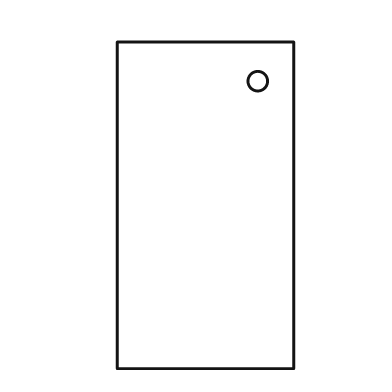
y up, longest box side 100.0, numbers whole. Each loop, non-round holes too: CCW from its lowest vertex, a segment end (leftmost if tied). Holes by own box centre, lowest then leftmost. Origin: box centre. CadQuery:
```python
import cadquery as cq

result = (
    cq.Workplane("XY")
    .moveTo(-27.0, -50.0)
    .lineTo(27.0, -50.0)
    .lineTo(27.0, 50.0)
    .lineTo(-27.0, 50.0)
    .close()
    .moveTo(16.0, 38.0)
    .circle(3.0)
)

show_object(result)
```